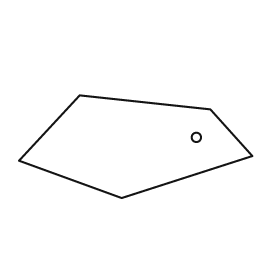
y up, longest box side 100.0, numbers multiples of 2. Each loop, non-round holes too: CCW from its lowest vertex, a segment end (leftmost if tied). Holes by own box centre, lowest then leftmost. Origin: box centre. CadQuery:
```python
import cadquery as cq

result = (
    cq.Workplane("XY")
    .moveTo(-6.0, -22.0)
    .lineTo(50.0, -4.0)
    .lineTo(32.0, 16.0)
    .lineTo(-24.0, 22.0)
    .lineTo(-50.0, -6.0)
    .close()
    .moveTo(26.0, 4.0)
    .circle(2.0)
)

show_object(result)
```